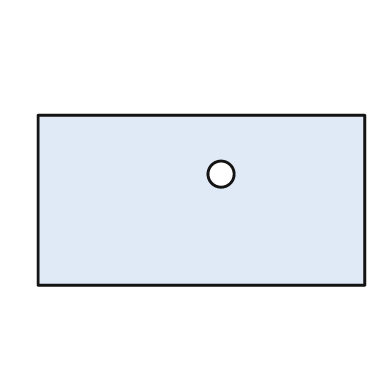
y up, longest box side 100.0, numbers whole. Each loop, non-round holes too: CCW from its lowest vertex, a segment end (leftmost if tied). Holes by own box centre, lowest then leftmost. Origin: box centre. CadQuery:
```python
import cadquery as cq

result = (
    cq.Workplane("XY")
    .moveTo(-50.0, -26.0)
    .lineTo(50.0, -26.0)
    .lineTo(50.0, 26.0)
    .lineTo(-50.0, 26.0)
    .close()
    .moveTo(6.0, 8.0)
    .circle(4.0)
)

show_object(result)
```